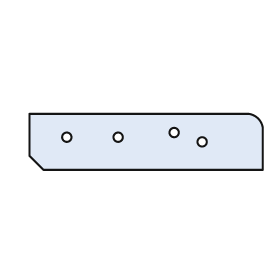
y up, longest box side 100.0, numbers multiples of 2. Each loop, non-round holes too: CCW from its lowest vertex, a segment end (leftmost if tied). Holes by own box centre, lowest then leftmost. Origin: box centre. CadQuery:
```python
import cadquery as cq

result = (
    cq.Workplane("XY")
    .moveTo(-44.0, -12.0)
    .lineTo(50.0, -12.0)
    .lineTo(50.0, 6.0)
    .threePointArc((48.0, 10.0), (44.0, 12.0))
    .lineTo(-50.0, 12.0)
    .lineTo(-50.0, -6.0)
    .close()
    .moveTo(24.0, 0.0)
    .circle(2.0)
    .moveTo(-34.0, 2.0)
    .circle(2.0)
    .moveTo(-12.0, 2.0)
    .circle(2.0)
    .moveTo(12.0, 4.0)
    .circle(2.0)
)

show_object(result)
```